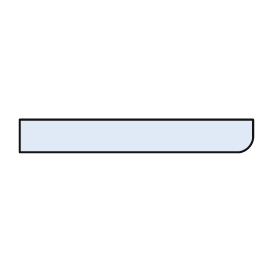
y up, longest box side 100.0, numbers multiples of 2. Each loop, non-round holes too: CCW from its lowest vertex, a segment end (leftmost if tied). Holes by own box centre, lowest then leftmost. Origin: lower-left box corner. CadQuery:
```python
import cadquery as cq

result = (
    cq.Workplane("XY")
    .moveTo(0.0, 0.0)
    .lineTo(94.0, 0.0)
    .threePointArc((98.0, 2.0), (100.0, 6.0))
    .lineTo(100.0, 14.0)
    .lineTo(0.0, 14.0)
    .close()
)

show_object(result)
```